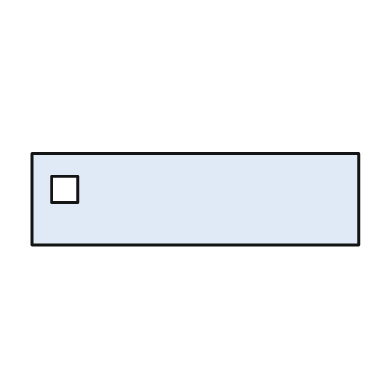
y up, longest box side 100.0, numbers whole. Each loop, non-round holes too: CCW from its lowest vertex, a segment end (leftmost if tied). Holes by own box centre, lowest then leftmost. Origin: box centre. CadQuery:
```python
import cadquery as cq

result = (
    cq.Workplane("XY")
    .moveTo(-50.0, -14.0)
    .lineTo(50.0, -14.0)
    .lineTo(50.0, 14.0)
    .lineTo(-50.0, 14.0)
    .close()
    .moveTo(-44.0, -1.0)
    .lineTo(-36.0, -1.0)
    .lineTo(-36.0, 7.0)
    .lineTo(-44.0, 7.0)
    .close()
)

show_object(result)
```